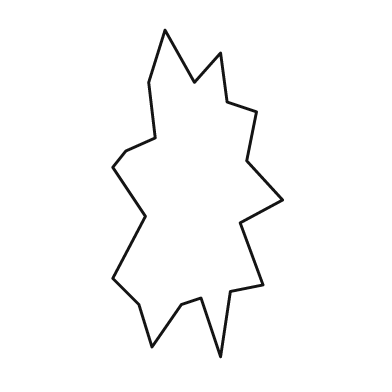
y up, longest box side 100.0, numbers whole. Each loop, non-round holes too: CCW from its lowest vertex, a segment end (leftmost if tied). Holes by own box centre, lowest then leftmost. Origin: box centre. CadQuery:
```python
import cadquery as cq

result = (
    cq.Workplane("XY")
    .moveTo(7.0, -50.0)
    .lineTo(10.0, -30.0)
    .lineTo(20.0, -28.0)
    .lineTo(13.0, -9.0)
    .lineTo(26.0, -2.0)
    .lineTo(15.0, 10.0)
    .lineTo(18.0, 25.0)
    .lineTo(9.0, 28.0)
    .lineTo(7.0, 43.0)
    .lineTo(-1.0, 34.0)
    .lineTo(-10.0, 50.0)
    .lineTo(-15.0, 34.0)
    .lineTo(-13.0, 17.0)
    .lineTo(-22.0, 13.0)
    .lineTo(-26.0, 8.0)
    .lineTo(-16.0, -7.0)
    .lineTo(-26.0, -26.0)
    .lineTo(-18.0, -34.0)
    .lineTo(-14.0, -47.0)
    .lineTo(-5.0, -34.0)
    .lineTo(1.0, -32.0)
    .close()
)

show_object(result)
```